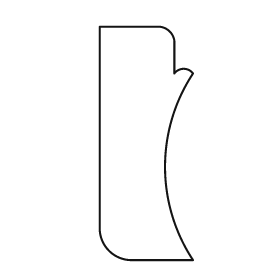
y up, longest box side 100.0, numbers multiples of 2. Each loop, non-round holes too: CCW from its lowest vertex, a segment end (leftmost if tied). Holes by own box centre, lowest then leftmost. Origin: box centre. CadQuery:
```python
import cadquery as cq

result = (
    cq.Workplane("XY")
    .moveTo(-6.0, -50.0)
    .lineTo(20.0, -50.0)
    .threePointArc((8.0, -10.0), (20.0, 30.0))
    .threePointArc((16.0, 32.0), (12.0, 30.0))
    .lineTo(12.0, 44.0)
    .threePointArc((10.0, 48.0), (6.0, 50.0))
    .lineTo(-20.0, 50.0)
    .lineTo(-20.0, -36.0)
    .threePointArc((-16.0, -46.0), (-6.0, -50.0))
    .close()
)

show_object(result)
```